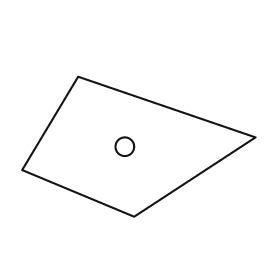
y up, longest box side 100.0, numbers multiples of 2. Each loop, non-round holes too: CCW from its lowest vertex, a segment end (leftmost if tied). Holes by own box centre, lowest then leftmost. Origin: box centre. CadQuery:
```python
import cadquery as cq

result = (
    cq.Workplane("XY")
    .moveTo(-2.0, -30.0)
    .lineTo(50.0, 4.0)
    .lineTo(-26.0, 30.0)
    .lineTo(-50.0, -10.0)
    .close()
    .moveTo(-6.0, 0.0)
    .circle(4.0)
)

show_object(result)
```